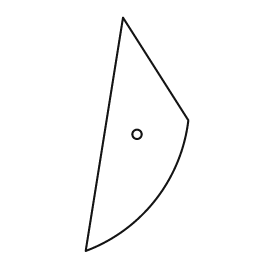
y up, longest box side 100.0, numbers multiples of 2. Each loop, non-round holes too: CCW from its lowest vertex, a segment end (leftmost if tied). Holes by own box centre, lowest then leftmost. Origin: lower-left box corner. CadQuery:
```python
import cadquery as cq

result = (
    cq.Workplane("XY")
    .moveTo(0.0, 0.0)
    .threePointArc((30.0, 22.0), (44.0, 56.0))
    .lineTo(16.0, 100.0)
    .close()
    .moveTo(22.0, 50.0)
    .circle(2.0)
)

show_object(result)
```